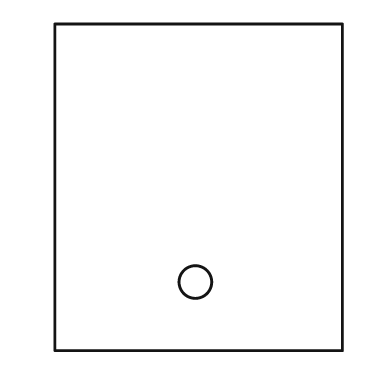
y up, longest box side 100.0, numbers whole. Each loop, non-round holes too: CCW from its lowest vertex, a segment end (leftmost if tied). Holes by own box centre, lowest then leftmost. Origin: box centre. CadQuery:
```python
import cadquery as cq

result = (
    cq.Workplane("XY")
    .moveTo(-44.0, -50.0)
    .lineTo(44.0, -50.0)
    .lineTo(44.0, 50.0)
    .lineTo(-44.0, 50.0)
    .close()
    .moveTo(-1.0, -29.0)
    .circle(5.0)
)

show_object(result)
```